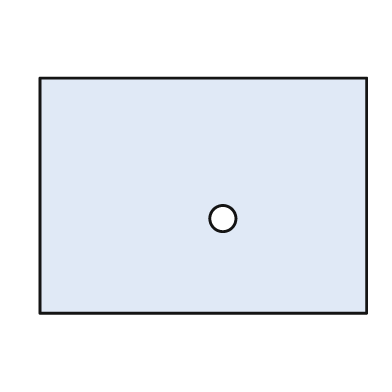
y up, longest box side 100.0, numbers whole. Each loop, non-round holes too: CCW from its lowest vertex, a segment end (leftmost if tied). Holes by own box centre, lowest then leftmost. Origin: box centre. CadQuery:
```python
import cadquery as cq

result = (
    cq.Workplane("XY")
    .moveTo(-50.0, -36.0)
    .lineTo(50.0, -36.0)
    .lineTo(50.0, 36.0)
    .lineTo(-50.0, 36.0)
    .close()
    .moveTo(6.0, -7.0)
    .circle(4.0)
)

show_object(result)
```